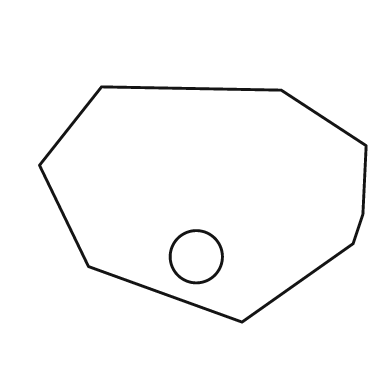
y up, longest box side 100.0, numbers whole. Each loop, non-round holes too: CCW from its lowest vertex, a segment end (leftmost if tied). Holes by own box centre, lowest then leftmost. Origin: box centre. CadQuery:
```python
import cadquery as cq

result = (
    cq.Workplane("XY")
    .moveTo(12.0, -36.0)
    .lineTo(46.0, -12.0)
    .lineTo(49.0, -3.0)
    .lineTo(50.0, 18.0)
    .lineTo(24.0, 35.0)
    .lineTo(-31.0, 36.0)
    .lineTo(-50.0, 12.0)
    .lineTo(-35.0, -19.0)
    .close()
    .moveTo(-2.0, -16.0)
    .circle(8.0)
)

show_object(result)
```